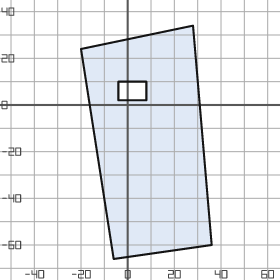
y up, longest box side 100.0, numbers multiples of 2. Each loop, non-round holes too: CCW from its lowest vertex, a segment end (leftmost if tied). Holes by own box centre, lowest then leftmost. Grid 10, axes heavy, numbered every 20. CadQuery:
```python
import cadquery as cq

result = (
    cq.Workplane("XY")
    .moveTo(-6.0, -66.0)
    .lineTo(36.0, -60.0)
    .lineTo(28.0, 34.0)
    .lineTo(-20.0, 24.0)
    .close()
    .moveTo(-4.0, 2.0)
    .lineTo(8.0, 2.0)
    .lineTo(8.0, 10.0)
    .lineTo(-4.0, 10.0)
    .close()
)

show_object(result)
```